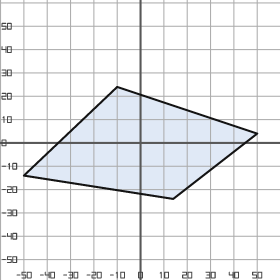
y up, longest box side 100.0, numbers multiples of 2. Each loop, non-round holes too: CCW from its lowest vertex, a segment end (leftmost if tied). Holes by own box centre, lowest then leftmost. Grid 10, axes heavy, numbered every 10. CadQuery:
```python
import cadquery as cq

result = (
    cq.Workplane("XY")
    .moveTo(14.0, -24.0)
    .lineTo(50.0, 4.0)
    .lineTo(-10.0, 24.0)
    .lineTo(-50.0, -14.0)
    .close()
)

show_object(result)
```